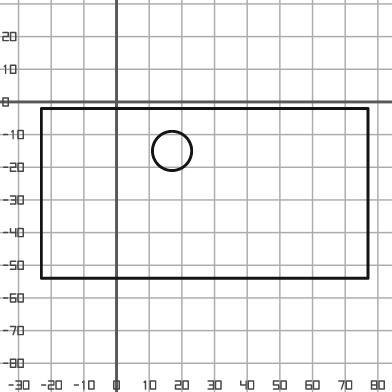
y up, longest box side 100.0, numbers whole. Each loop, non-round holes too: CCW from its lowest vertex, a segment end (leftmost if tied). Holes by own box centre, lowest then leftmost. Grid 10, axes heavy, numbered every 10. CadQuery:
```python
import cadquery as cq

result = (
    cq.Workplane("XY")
    .moveTo(-23.0, -54.0)
    .lineTo(77.0, -54.0)
    .lineTo(77.0, -2.0)
    .lineTo(-23.0, -2.0)
    .close()
    .moveTo(17.0, -15.0)
    .circle(6.0)
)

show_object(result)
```